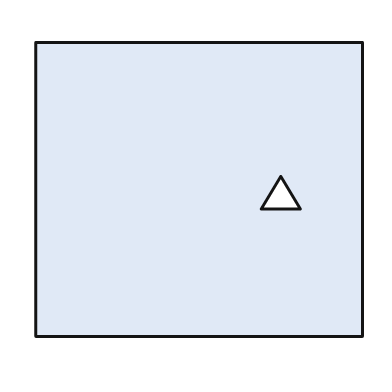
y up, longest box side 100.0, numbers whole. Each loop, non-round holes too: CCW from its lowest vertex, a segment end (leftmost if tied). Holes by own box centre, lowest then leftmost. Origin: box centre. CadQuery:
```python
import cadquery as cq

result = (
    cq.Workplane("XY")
    .moveTo(-50.0, -45.0)
    .lineTo(50.0, -45.0)
    .lineTo(50.0, 45.0)
    .lineTo(-50.0, 45.0)
    .close()
    .moveTo(19.0, -6.0)
    .lineTo(31.0, -6.0)
    .lineTo(25.0, 4.0)
    .close()
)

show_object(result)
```